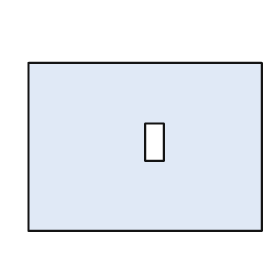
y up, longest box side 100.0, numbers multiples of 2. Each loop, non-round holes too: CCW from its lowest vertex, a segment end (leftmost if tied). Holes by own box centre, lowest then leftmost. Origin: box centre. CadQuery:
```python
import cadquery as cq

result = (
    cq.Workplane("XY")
    .moveTo(-50.0, -36.0)
    .lineTo(50.0, -36.0)
    .lineTo(50.0, 36.0)
    .lineTo(-50.0, 36.0)
    .close()
    .moveTo(0.0, -6.0)
    .lineTo(8.0, -6.0)
    .lineTo(8.0, 10.0)
    .lineTo(0.0, 10.0)
    .close()
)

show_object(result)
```